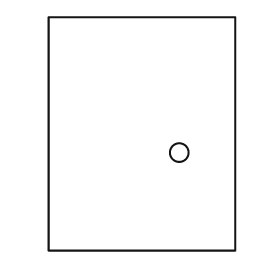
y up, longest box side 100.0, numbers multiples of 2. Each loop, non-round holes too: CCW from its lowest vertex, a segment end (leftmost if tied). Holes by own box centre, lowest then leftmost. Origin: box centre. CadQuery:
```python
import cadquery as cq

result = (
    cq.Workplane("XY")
    .moveTo(-40.0, -50.0)
    .lineTo(40.0, -50.0)
    .lineTo(40.0, 50.0)
    .lineTo(-40.0, 50.0)
    .close()
    .moveTo(16.0, -8.0)
    .circle(4.0)
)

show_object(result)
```